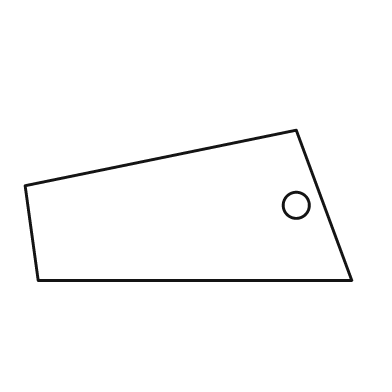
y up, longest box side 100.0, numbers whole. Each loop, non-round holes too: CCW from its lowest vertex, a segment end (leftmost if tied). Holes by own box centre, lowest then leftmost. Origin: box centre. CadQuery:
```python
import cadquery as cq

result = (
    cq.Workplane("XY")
    .moveTo(-46.0, -23.0)
    .lineTo(50.0, -23.0)
    .lineTo(33.0, 23.0)
    .lineTo(-50.0, 6.0)
    .close()
    .moveTo(33.0, 0.0)
    .circle(4.0)
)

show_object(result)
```